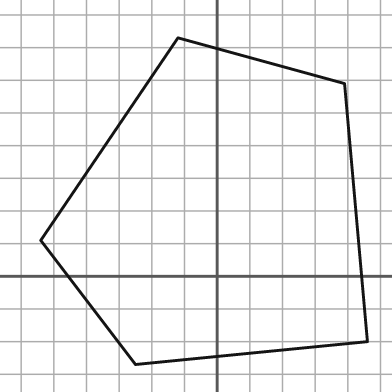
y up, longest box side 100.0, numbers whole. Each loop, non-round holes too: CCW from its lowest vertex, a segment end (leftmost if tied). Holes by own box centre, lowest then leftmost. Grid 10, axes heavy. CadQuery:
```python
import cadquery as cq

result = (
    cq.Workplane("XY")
    .moveTo(-25.0, -27.0)
    .lineTo(46.0, -20.0)
    .lineTo(39.0, 59.0)
    .lineTo(-12.0, 73.0)
    .lineTo(-54.0, 11.0)
    .close()
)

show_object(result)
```